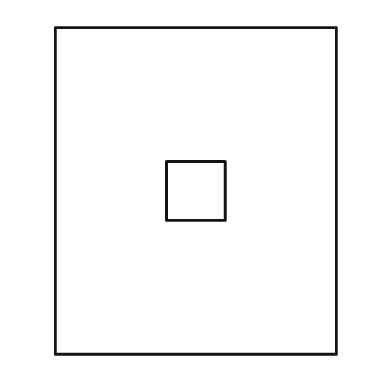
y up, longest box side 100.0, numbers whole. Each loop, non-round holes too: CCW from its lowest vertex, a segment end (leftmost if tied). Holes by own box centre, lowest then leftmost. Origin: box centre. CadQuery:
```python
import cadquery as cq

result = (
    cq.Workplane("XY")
    .moveTo(-43.0, -50.0)
    .lineTo(43.0, -50.0)
    .lineTo(43.0, 50.0)
    .lineTo(-43.0, 50.0)
    .close()
    .moveTo(-9.0, -9.0)
    .lineTo(9.0, -9.0)
    .lineTo(9.0, 9.0)
    .lineTo(-9.0, 9.0)
    .close()
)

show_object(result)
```